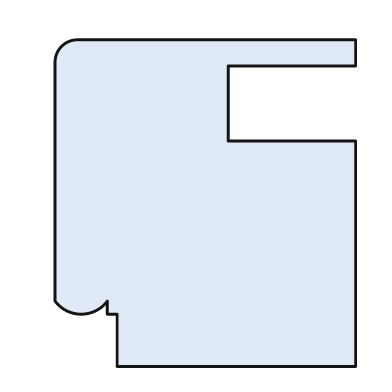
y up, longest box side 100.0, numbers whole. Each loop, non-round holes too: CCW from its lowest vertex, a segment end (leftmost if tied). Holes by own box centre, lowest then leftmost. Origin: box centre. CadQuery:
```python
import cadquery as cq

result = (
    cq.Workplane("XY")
    .moveTo(-27.0, -50.0)
    .lineTo(46.0, -50.0)
    .lineTo(46.0, 19.0)
    .lineTo(7.0, 19.0)
    .lineTo(7.0, 42.0)
    .lineTo(46.0, 42.0)
    .lineTo(46.0, 50.0)
    .lineTo(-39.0, 50.0)
    .threePointArc((-44.0, 48.0), (-46.0, 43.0))
    .lineTo(-46.0, -30.0)
    .threePointArc((-38.0, -34.0), (-30.0, -30.0))
    .lineTo(-30.0, -34.0)
    .lineTo(-27.0, -34.0)
    .close()
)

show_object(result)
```